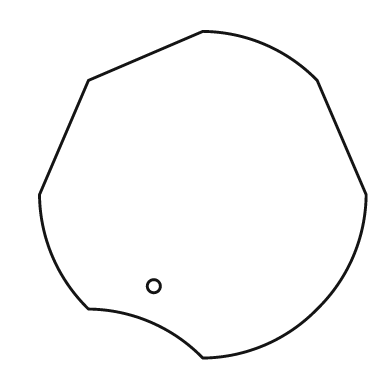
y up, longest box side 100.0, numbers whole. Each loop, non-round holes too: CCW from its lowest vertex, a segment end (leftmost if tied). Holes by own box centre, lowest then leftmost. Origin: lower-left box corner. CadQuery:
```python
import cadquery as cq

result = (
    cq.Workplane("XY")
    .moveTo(50.0, 0.0)
    .threePointArc((69.0, 4.0), (85.0, 15.0))
    .threePointArc((96.0, 31.0), (100.0, 50.0))
    .lineTo(85.0, 85.0)
    .threePointArc((69.0, 96.0), (50.0, 100.0))
    .lineTo(15.0, 85.0)
    .lineTo(0.0, 50.0)
    .threePointArc((4.0, 31.0), (15.0, 15.0))
    .threePointArc((34.0, 11.0), (50.0, 0.0))
    .close()
    .moveTo(35.0, 22.0)
    .circle(2.0)
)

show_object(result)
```